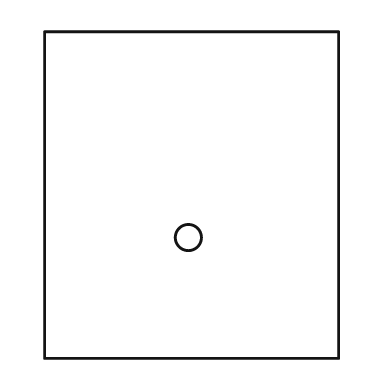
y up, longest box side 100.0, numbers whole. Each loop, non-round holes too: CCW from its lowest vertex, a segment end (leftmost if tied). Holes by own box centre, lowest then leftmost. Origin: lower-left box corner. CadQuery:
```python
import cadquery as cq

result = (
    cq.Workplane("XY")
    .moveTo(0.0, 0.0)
    .lineTo(90.0, 0.0)
    .lineTo(90.0, 100.0)
    .lineTo(0.0, 100.0)
    .close()
    .moveTo(44.0, 37.0)
    .circle(4.0)
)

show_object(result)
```